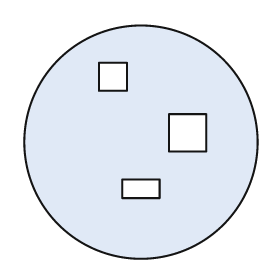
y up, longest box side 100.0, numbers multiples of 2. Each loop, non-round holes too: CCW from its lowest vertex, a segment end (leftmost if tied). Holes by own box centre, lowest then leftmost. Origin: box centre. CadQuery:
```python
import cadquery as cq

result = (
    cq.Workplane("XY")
    .moveTo(0.0, 0.0)
    .circle(50.0)
    .moveTo(-8.0, -24.0)
    .lineTo(8.0, -24.0)
    .lineTo(8.0, -16.0)
    .lineTo(-8.0, -16.0)
    .close()
    .moveTo(12.0, -4.0)
    .lineTo(28.0, -4.0)
    .lineTo(28.0, 12.0)
    .lineTo(12.0, 12.0)
    .close()
    .moveTo(-18.0, 22.0)
    .lineTo(-6.0, 22.0)
    .lineTo(-6.0, 34.0)
    .lineTo(-18.0, 34.0)
    .close()
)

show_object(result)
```